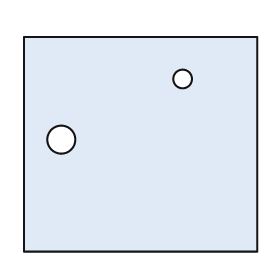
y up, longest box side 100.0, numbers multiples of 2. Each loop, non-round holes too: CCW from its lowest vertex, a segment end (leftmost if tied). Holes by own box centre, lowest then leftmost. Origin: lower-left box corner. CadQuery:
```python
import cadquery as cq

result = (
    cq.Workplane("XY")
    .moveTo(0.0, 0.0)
    .lineTo(100.0, 0.0)
    .lineTo(100.0, 92.0)
    .lineTo(0.0, 92.0)
    .close()
    .moveTo(16.0, 48.0)
    .circle(6.0)
    .moveTo(68.0, 74.0)
    .circle(4.0)
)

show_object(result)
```